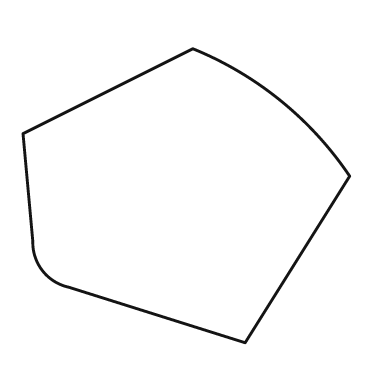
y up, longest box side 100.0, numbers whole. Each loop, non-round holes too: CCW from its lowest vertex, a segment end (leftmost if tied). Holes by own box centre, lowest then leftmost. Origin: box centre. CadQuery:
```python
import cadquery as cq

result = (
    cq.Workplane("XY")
    .moveTo(18.0, -45.0)
    .lineTo(50.0, 6.0)
    .threePointArc((29.0, 29.0), (2.0, 45.0))
    .lineTo(-50.0, 19.0)
    .lineTo(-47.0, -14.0)
    .threePointArc((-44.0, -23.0), (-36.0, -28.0))
    .close()
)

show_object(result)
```